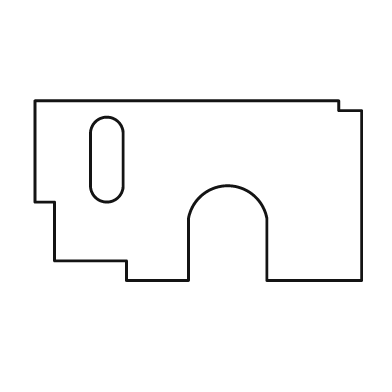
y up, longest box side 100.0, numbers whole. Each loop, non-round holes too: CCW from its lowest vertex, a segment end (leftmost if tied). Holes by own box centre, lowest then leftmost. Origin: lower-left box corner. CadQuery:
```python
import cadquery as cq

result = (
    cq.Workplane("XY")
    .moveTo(28.0, 0.0)
    .lineTo(47.0, 0.0)
    .lineTo(47.0, 19.0)
    .threePointArc((59.0, 29.0), (71.0, 19.0))
    .lineTo(71.0, 0.0)
    .lineTo(100.0, 0.0)
    .lineTo(100.0, 52.0)
    .lineTo(93.0, 52.0)
    .lineTo(93.0, 55.0)
    .lineTo(0.0, 55.0)
    .lineTo(0.0, 24.0)
    .lineTo(6.0, 24.0)
    .lineTo(6.0, 6.0)
    .lineTo(28.0, 6.0)
    .close()
    .moveTo(17.0, 29.0)
    .threePointArc((22.0, 24.0), (27.0, 29.0))
    .lineTo(27.0, 45.0)
    .threePointArc((22.0, 50.0), (17.0, 45.0))
    .close()
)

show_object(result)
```